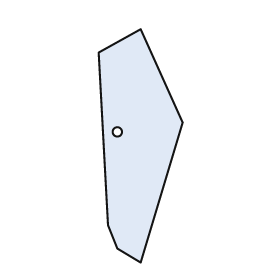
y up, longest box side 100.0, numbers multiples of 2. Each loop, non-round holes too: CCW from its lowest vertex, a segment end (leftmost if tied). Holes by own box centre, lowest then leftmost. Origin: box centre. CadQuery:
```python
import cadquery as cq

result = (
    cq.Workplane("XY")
    .moveTo(0.0, -50.0)
    .lineTo(18.0, 10.0)
    .lineTo(0.0, 50.0)
    .lineTo(-18.0, 40.0)
    .lineTo(-14.0, -34.0)
    .lineTo(-10.0, -44.0)
    .close()
    .moveTo(-10.0, 6.0)
    .circle(2.0)
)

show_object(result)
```